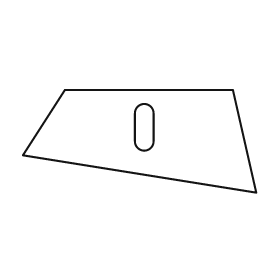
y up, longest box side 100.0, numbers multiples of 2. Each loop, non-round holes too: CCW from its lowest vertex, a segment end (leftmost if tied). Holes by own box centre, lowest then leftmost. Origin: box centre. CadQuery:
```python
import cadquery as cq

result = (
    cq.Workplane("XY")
    .moveTo(50.0, -22.0)
    .lineTo(40.0, 22.0)
    .lineTo(-32.0, 22.0)
    .lineTo(-50.0, -6.0)
    .close()
    .moveTo(-2.0, 0.0)
    .threePointArc((2.0, -4.0), (6.0, 0.0))
    .lineTo(6.0, 12.0)
    .threePointArc((2.0, 16.0), (-2.0, 12.0))
    .close()
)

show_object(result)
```